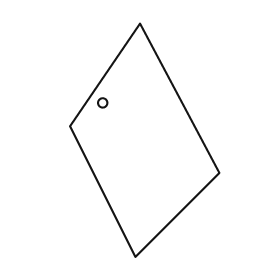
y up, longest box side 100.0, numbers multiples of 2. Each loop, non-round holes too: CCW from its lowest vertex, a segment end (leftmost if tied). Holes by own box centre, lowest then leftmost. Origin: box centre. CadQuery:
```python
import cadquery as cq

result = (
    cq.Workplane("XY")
    .moveTo(-4.0, -50.0)
    .lineTo(32.0, -14.0)
    .lineTo(-2.0, 50.0)
    .lineTo(-32.0, 6.0)
    .close()
    .moveTo(-18.0, 16.0)
    .circle(2.0)
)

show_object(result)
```